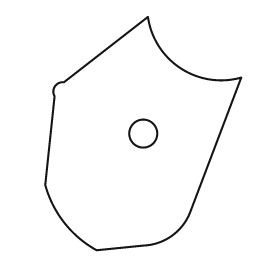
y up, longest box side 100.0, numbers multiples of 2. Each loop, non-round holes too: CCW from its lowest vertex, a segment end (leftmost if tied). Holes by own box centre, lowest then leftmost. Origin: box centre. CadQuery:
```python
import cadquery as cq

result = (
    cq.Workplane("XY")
    .moveTo(-20.0, -50.0)
    .lineTo(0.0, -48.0)
    .threePointArc((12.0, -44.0), (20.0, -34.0))
    .lineTo(42.0, 24.0)
    .threePointArc((16.0, 28.0), (2.0, 50.0))
    .lineTo(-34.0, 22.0)
    .threePointArc((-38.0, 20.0), (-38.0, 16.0))
    .lineTo(-42.0, -22.0)
    .threePointArc((-34.0, -38.0), (-20.0, -50.0))
    .close()
    .moveTo(0.0, 0.0)
    .circle(6.0)
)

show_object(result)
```